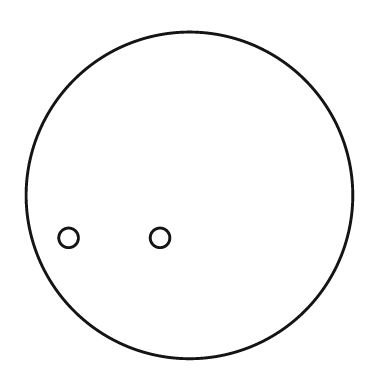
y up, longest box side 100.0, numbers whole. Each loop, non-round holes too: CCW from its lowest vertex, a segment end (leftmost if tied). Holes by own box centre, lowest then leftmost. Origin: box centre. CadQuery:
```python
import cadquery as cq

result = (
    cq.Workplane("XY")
    .moveTo(0.0, 0.0)
    .circle(50.0)
    .moveTo(-37.0, -13.0)
    .circle(3.0)
    .moveTo(-9.0, -13.0)
    .circle(3.0)
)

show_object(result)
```